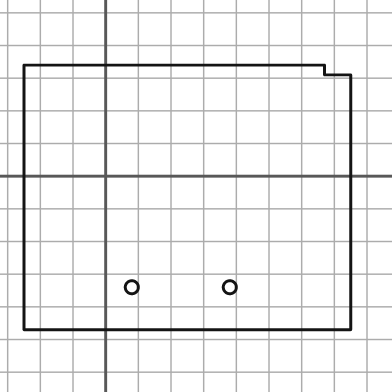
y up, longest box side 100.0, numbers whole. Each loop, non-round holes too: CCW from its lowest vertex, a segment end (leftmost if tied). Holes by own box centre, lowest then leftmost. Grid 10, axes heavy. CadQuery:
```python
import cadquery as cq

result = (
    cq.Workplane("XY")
    .moveTo(-25.0, -47.0)
    .lineTo(75.0, -47.0)
    .lineTo(75.0, 31.0)
    .lineTo(67.0, 31.0)
    .lineTo(67.0, 34.0)
    .lineTo(-25.0, 34.0)
    .close()
    .moveTo(8.0, -34.0)
    .circle(2.0)
    .moveTo(38.0, -34.0)
    .circle(2.0)
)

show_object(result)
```